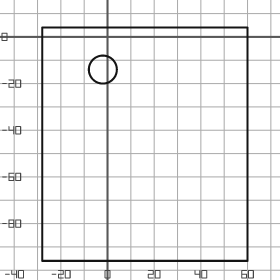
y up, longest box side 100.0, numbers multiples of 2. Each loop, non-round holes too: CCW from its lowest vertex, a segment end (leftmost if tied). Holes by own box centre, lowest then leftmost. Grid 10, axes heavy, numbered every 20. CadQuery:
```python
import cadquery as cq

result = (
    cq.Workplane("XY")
    .moveTo(-28.0, -96.0)
    .lineTo(60.0, -96.0)
    .lineTo(60.0, 4.0)
    .lineTo(-28.0, 4.0)
    .close()
    .moveTo(-2.0, -14.0)
    .circle(6.0)
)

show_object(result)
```